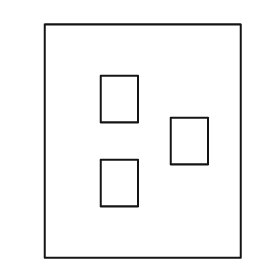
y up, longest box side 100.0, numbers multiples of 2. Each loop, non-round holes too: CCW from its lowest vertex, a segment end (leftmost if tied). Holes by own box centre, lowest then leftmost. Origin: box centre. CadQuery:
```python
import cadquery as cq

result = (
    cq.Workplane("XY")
    .moveTo(-42.0, -50.0)
    .lineTo(42.0, -50.0)
    .lineTo(42.0, 50.0)
    .lineTo(-42.0, 50.0)
    .close()
    .moveTo(-18.0, -28.0)
    .lineTo(-2.0, -28.0)
    .lineTo(-2.0, -8.0)
    .lineTo(-18.0, -8.0)
    .close()
    .moveTo(12.0, -10.0)
    .lineTo(28.0, -10.0)
    .lineTo(28.0, 10.0)
    .lineTo(12.0, 10.0)
    .close()
    .moveTo(-18.0, 8.0)
    .lineTo(-2.0, 8.0)
    .lineTo(-2.0, 28.0)
    .lineTo(-18.0, 28.0)
    .close()
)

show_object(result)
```